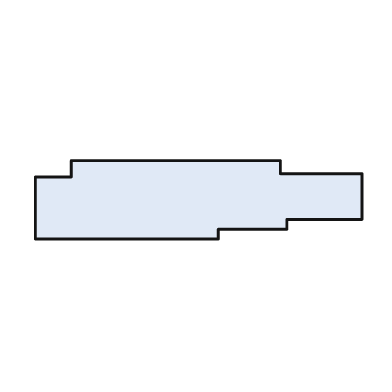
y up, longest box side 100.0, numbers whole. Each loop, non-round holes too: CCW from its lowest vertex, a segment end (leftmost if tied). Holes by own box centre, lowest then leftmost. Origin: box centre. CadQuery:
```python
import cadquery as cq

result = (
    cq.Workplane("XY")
    .moveTo(-50.0, -12.0)
    .lineTo(6.0, -12.0)
    .lineTo(6.0, -9.0)
    .lineTo(27.0, -9.0)
    .lineTo(27.0, -6.0)
    .lineTo(50.0, -6.0)
    .lineTo(50.0, 8.0)
    .lineTo(25.0, 8.0)
    .lineTo(25.0, 12.0)
    .lineTo(-39.0, 12.0)
    .lineTo(-39.0, 7.0)
    .lineTo(-50.0, 7.0)
    .close()
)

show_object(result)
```